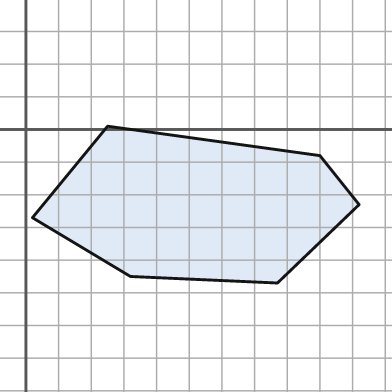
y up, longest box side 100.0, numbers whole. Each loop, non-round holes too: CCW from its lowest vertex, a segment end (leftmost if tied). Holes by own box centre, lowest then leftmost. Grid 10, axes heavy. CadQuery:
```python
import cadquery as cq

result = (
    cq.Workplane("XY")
    .moveTo(77.0, -47.0)
    .lineTo(102.0, -23.0)
    .lineTo(90.0, -8.0)
    .lineTo(25.0, 1.0)
    .lineTo(2.0, -27.0)
    .lineTo(32.0, -45.0)
    .close()
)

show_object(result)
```